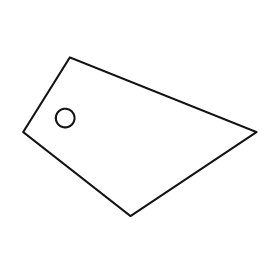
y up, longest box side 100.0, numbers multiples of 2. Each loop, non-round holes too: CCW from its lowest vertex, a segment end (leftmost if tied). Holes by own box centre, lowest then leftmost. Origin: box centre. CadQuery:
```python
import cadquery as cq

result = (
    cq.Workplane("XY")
    .moveTo(-4.0, -34.0)
    .lineTo(50.0, 2.0)
    .lineTo(-30.0, 34.0)
    .lineTo(-50.0, 2.0)
    .close()
    .moveTo(-32.0, 8.0)
    .circle(4.0)
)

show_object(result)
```